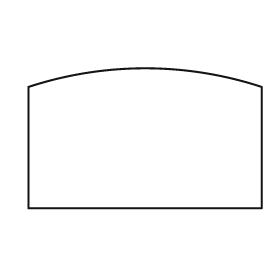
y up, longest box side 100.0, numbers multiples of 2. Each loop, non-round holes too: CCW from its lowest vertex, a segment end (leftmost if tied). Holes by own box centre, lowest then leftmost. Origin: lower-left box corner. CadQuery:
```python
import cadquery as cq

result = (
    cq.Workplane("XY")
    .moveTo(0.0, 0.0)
    .lineTo(100.0, 0.0)
    .lineTo(100.0, 52.0)
    .threePointArc((50.0, 60.0), (0.0, 52.0))
    .close()
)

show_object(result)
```